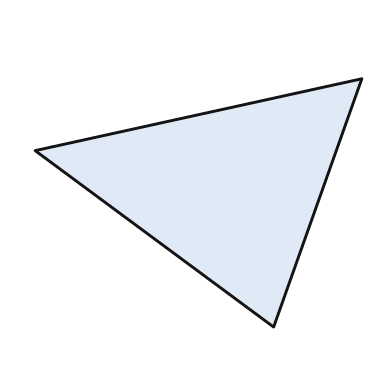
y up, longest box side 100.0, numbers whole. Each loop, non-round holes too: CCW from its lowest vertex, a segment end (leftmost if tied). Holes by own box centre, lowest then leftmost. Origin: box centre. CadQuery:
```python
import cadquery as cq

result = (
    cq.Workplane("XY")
    .moveTo(23.0, -38.0)
    .lineTo(50.0, 38.0)
    .lineTo(-50.0, 16.0)
    .close()
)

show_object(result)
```